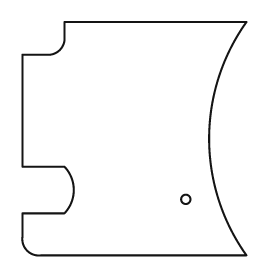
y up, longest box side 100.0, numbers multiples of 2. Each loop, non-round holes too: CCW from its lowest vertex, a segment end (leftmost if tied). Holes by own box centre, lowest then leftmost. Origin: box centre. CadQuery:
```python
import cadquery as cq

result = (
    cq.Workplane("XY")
    .moveTo(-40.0, -50.0)
    .lineTo(48.0, -50.0)
    .threePointArc((32.0, 0.0), (48.0, 50.0))
    .lineTo(-30.0, 50.0)
    .lineTo(-30.0, 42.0)
    .threePointArc((-32.0, 38.0), (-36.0, 36.0))
    .lineTo(-48.0, 36.0)
    .lineTo(-48.0, -12.0)
    .lineTo(-30.0, -12.0)
    .threePointArc((-26.0, -22.0), (-30.0, -32.0))
    .lineTo(-48.0, -32.0)
    .lineTo(-48.0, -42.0)
    .threePointArc((-46.0, -48.0), (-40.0, -50.0))
    .close()
    .moveTo(22.0, -26.0)
    .circle(2.0)
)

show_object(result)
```